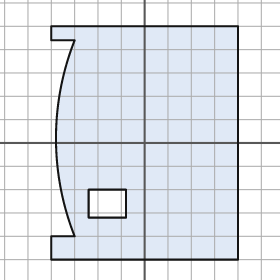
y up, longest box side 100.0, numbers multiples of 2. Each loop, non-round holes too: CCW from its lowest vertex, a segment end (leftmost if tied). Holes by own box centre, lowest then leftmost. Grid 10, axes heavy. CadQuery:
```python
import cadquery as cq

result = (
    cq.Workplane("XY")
    .moveTo(-40.0, -50.0)
    .lineTo(40.0, -50.0)
    .lineTo(40.0, 50.0)
    .lineTo(-40.0, 50.0)
    .lineTo(-40.0, 44.0)
    .lineTo(-30.0, 44.0)
    .threePointArc((-38.0, 2.0), (-30.0, -40.0))
    .lineTo(-40.0, -40.0)
    .close()
    .moveTo(-24.0, -32.0)
    .lineTo(-8.0, -32.0)
    .lineTo(-8.0, -20.0)
    .lineTo(-24.0, -20.0)
    .close()
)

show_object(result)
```